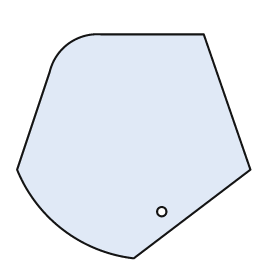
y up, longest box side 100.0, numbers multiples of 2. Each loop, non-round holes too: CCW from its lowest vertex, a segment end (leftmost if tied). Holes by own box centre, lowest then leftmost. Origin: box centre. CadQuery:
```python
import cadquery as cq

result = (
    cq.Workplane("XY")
    .moveTo(0.0, -48.0)
    .lineTo(50.0, -10.0)
    .lineTo(30.0, 48.0)
    .lineTo(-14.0, 48.0)
    .threePointArc((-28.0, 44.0), (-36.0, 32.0))
    .lineTo(-50.0, -10.0)
    .threePointArc((-30.0, -36.0), (0.0, -48.0))
    .close()
    .moveTo(12.0, -28.0)
    .circle(2.0)
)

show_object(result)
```